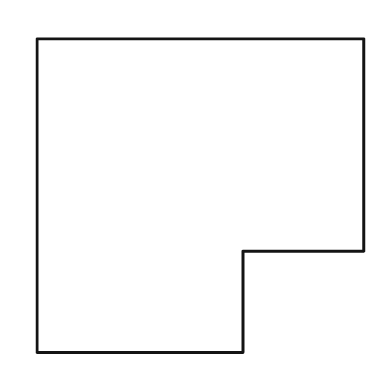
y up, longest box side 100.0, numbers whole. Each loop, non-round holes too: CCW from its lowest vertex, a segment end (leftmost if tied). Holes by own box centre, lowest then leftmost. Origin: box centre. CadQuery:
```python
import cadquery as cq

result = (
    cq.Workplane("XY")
    .moveTo(-50.0, -48.0)
    .lineTo(13.0, -48.0)
    .lineTo(13.0, -17.0)
    .lineTo(50.0, -17.0)
    .lineTo(50.0, 48.0)
    .lineTo(-50.0, 48.0)
    .close()
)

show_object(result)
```